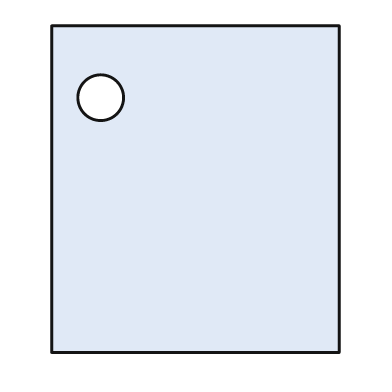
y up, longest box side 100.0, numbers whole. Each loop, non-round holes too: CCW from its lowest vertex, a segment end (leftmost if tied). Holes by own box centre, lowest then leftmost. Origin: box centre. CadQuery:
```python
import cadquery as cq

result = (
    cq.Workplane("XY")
    .moveTo(-44.0, -50.0)
    .lineTo(44.0, -50.0)
    .lineTo(44.0, 50.0)
    .lineTo(-44.0, 50.0)
    .close()
    .moveTo(-29.0, 28.0)
    .circle(7.0)
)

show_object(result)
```